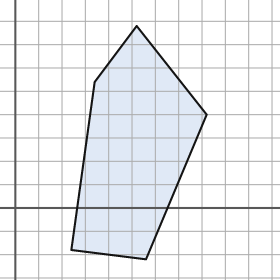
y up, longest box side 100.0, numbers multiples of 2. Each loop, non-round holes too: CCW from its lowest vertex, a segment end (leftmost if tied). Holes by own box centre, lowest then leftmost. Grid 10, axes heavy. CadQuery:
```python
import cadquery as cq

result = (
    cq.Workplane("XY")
    .moveTo(56.0, -22.0)
    .lineTo(82.0, 40.0)
    .lineTo(52.0, 78.0)
    .lineTo(34.0, 54.0)
    .lineTo(24.0, -18.0)
    .close()
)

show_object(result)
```